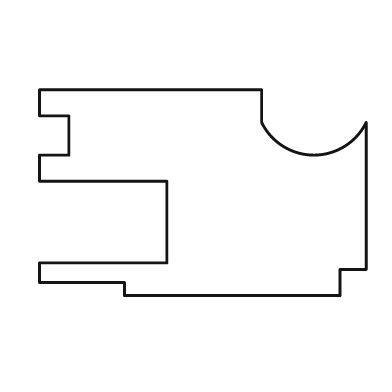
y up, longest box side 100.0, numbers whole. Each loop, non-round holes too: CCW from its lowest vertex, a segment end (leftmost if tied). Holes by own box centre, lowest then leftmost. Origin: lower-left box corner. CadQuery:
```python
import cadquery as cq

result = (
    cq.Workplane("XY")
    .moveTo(26.0, 0.0)
    .lineTo(92.0, 0.0)
    .lineTo(92.0, 8.0)
    .lineTo(100.0, 8.0)
    .lineTo(100.0, 53.0)
    .threePointArc((84.0, 43.0), (68.0, 53.0))
    .lineTo(68.0, 63.0)
    .lineTo(0.0, 63.0)
    .lineTo(0.0, 55.0)
    .lineTo(9.0, 55.0)
    .lineTo(9.0, 43.0)
    .lineTo(0.0, 43.0)
    .lineTo(0.0, 35.0)
    .lineTo(39.0, 35.0)
    .lineTo(39.0, 10.0)
    .lineTo(0.0, 10.0)
    .lineTo(0.0, 4.0)
    .lineTo(26.0, 4.0)
    .close()
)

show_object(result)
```